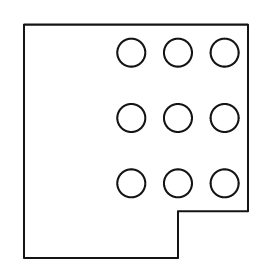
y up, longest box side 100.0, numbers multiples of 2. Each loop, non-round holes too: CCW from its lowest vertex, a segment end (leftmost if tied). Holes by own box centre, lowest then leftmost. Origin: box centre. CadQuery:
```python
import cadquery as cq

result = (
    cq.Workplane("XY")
    .moveTo(-48.0, -50.0)
    .lineTo(18.0, -50.0)
    .lineTo(18.0, -30.0)
    .lineTo(48.0, -30.0)
    .lineTo(48.0, 50.0)
    .lineTo(-48.0, 50.0)
    .close()
    .moveTo(-2.0, -18.0)
    .circle(6.0)
    .moveTo(18.0, -18.0)
    .circle(6.0)
    .moveTo(38.0, -18.0)
    .circle(6.0)
    .moveTo(-2.0, 10.0)
    .circle(6.0)
    .moveTo(18.0, 10.0)
    .circle(6.0)
    .moveTo(38.0, 10.0)
    .circle(6.0)
    .moveTo(-2.0, 38.0)
    .circle(6.0)
    .moveTo(18.0, 38.0)
    .circle(6.0)
    .moveTo(38.0, 38.0)
    .circle(6.0)
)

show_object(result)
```